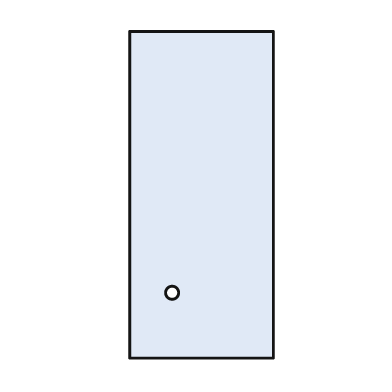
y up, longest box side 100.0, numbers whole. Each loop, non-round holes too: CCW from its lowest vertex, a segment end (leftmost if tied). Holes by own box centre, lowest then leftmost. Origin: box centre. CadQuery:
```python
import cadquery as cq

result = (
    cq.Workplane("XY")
    .moveTo(-22.0, -50.0)
    .lineTo(22.0, -50.0)
    .lineTo(22.0, 50.0)
    .lineTo(-22.0, 50.0)
    .close()
    .moveTo(-9.0, -30.0)
    .circle(2.0)
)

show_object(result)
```